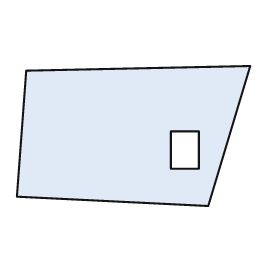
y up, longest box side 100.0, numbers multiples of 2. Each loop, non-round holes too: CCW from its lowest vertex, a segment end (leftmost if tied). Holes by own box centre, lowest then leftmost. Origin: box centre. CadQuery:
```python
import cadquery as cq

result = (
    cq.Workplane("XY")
    .moveTo(32.0, -30.0)
    .lineTo(50.0, 30.0)
    .lineTo(-46.0, 28.0)
    .lineTo(-50.0, -26.0)
    .close()
    .moveTo(16.0, -14.0)
    .lineTo(28.0, -14.0)
    .lineTo(28.0, 2.0)
    .lineTo(16.0, 2.0)
    .close()
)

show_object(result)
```